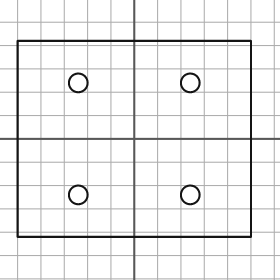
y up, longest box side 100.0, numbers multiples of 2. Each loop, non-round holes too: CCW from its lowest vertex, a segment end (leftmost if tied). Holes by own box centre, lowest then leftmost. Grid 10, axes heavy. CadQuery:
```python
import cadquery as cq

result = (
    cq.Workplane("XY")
    .moveTo(-50.0, -42.0)
    .lineTo(50.0, -42.0)
    .lineTo(50.0, 42.0)
    .lineTo(-50.0, 42.0)
    .close()
    .moveTo(-24.0, -24.0)
    .circle(4.0)
    .moveTo(24.0, -24.0)
    .circle(4.0)
    .moveTo(-24.0, 24.0)
    .circle(4.0)
    .moveTo(24.0, 24.0)
    .circle(4.0)
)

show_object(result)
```